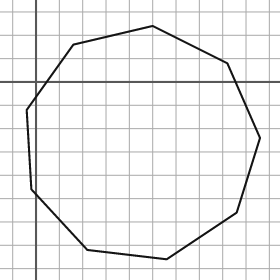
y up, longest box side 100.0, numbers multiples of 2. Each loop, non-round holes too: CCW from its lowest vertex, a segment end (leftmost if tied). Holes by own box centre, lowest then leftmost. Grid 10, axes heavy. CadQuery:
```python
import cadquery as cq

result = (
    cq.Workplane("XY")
    .moveTo(56.0, -76.0)
    .lineTo(86.0, -56.0)
    .lineTo(96.0, -24.0)
    .lineTo(82.0, 8.0)
    .lineTo(50.0, 24.0)
    .lineTo(16.0, 16.0)
    .lineTo(-4.0, -12.0)
    .lineTo(-2.0, -46.0)
    .lineTo(22.0, -72.0)
    .close()
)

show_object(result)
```